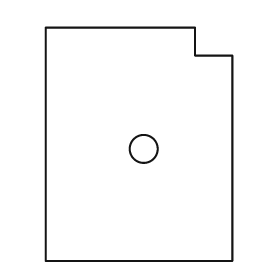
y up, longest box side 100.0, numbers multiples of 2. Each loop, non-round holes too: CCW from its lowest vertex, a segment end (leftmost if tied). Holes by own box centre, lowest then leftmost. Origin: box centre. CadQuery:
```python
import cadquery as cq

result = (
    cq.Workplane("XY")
    .moveTo(-40.0, -50.0)
    .lineTo(40.0, -50.0)
    .lineTo(40.0, 38.0)
    .lineTo(24.0, 38.0)
    .lineTo(24.0, 50.0)
    .lineTo(-40.0, 50.0)
    .close()
    .moveTo(2.0, -2.0)
    .circle(6.0)
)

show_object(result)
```